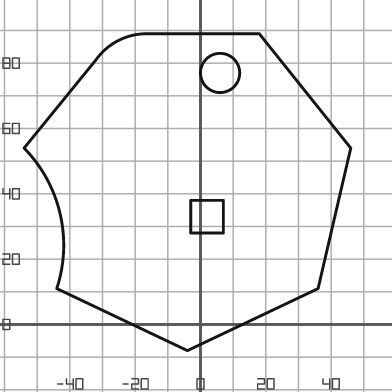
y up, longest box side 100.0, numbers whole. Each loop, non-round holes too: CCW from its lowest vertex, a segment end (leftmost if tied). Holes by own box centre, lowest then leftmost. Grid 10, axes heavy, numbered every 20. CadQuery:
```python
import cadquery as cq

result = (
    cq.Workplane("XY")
    .moveTo(-4.0, -8.0)
    .lineTo(36.0, 11.0)
    .lineTo(46.0, 54.0)
    .lineTo(18.0, 89.0)
    .lineTo(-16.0, 89.0)
    .threePointArc((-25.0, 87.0), (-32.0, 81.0))
    .lineTo(-54.0, 54.0)
    .threePointArc((-43.0, 34.0), (-44.0, 11.0))
    .close()
    .moveTo(-3.0, 28.0)
    .lineTo(7.0, 28.0)
    .lineTo(7.0, 38.0)
    .lineTo(-3.0, 38.0)
    .close()
    .moveTo(6.0, 77.0)
    .circle(6.0)
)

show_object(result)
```